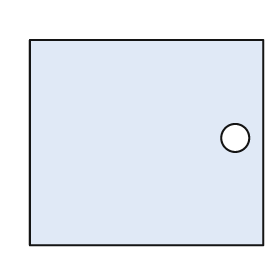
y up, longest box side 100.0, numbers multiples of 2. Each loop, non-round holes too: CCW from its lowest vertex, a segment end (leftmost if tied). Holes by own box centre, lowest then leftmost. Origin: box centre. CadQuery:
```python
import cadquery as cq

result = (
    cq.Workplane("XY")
    .moveTo(-50.0, -44.0)
    .lineTo(50.0, -44.0)
    .lineTo(50.0, 44.0)
    .lineTo(-50.0, 44.0)
    .close()
    .moveTo(38.0, 2.0)
    .circle(6.0)
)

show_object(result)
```